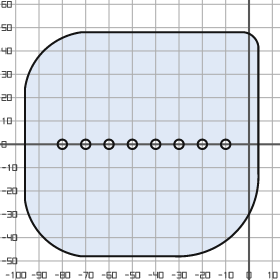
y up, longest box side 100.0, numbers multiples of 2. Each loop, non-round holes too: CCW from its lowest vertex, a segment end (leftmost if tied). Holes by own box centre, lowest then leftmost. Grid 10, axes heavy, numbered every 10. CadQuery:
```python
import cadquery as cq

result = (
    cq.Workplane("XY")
    .moveTo(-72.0, -48.0)
    .lineTo(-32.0, -48.0)
    .threePointArc((-6.0, -38.0), (4.0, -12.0))
    .lineTo(4.0, 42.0)
    .threePointArc((2.0, 46.0), (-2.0, 48.0))
    .lineTo(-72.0, 48.0)
    .threePointArc((-88.0, 40.0), (-96.0, 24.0))
    .lineTo(-96.0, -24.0)
    .threePointArc((-88.0, -40.0), (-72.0, -48.0))
    .close()
    .moveTo(-80.0, 0.0)
    .circle(2.0)
    .moveTo(-70.0, 0.0)
    .circle(2.0)
    .moveTo(-60.0, 0.0)
    .circle(2.0)
    .moveTo(-50.0, 0.0)
    .circle(2.0)
    .moveTo(-40.0, 0.0)
    .circle(2.0)
    .moveTo(-30.0, 0.0)
    .circle(2.0)
    .moveTo(-20.0, 0.0)
    .circle(2.0)
    .moveTo(-10.0, 0.0)
    .circle(2.0)
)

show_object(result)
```